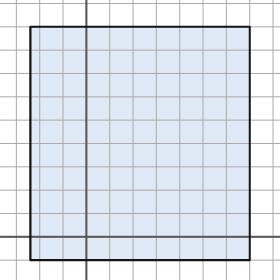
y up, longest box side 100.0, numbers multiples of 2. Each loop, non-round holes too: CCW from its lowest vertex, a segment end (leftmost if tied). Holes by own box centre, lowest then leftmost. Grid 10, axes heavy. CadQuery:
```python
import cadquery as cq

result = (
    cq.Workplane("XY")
    .moveTo(-24.0, -10.0)
    .lineTo(70.0, -10.0)
    .lineTo(70.0, 90.0)
    .lineTo(-24.0, 90.0)
    .close()
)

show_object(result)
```